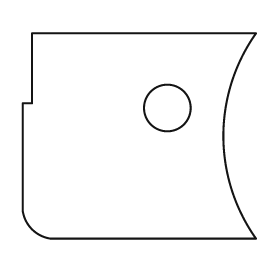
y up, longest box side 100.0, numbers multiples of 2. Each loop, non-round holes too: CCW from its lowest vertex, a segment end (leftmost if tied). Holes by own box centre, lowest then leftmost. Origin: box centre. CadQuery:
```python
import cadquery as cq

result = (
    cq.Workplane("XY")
    .moveTo(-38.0, -44.0)
    .lineTo(50.0, -44.0)
    .threePointArc((36.0, 0.0), (50.0, 44.0))
    .lineTo(-46.0, 44.0)
    .lineTo(-46.0, 14.0)
    .lineTo(-50.0, 14.0)
    .lineTo(-50.0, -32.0)
    .threePointArc((-46.0, -40.0), (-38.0, -44.0))
    .close()
    .moveTo(12.0, 12.0)
    .circle(10.0)
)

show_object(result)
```